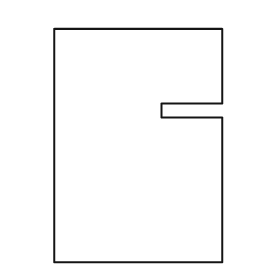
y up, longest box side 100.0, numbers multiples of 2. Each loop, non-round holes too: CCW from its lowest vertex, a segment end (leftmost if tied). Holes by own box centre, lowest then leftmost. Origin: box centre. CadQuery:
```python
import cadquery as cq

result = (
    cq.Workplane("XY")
    .moveTo(-36.0, -50.0)
    .lineTo(36.0, -50.0)
    .lineTo(36.0, 12.0)
    .lineTo(10.0, 12.0)
    .lineTo(10.0, 18.0)
    .lineTo(36.0, 18.0)
    .lineTo(36.0, 50.0)
    .lineTo(-36.0, 50.0)
    .close()
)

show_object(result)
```